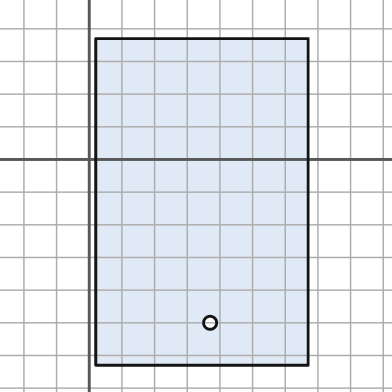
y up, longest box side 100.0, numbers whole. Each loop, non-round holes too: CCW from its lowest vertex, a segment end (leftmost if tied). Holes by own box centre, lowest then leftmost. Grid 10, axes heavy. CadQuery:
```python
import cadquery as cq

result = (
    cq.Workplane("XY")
    .moveTo(2.0, -63.0)
    .lineTo(67.0, -63.0)
    .lineTo(67.0, 37.0)
    .lineTo(2.0, 37.0)
    .close()
    .moveTo(37.0, -50.0)
    .circle(2.0)
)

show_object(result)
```